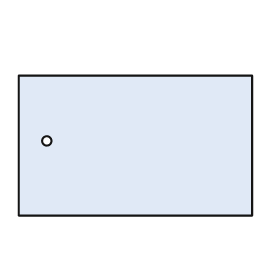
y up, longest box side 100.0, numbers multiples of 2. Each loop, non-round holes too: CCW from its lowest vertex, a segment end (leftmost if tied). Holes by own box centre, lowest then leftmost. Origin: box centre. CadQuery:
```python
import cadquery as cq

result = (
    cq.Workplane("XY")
    .moveTo(-50.0, -30.0)
    .lineTo(50.0, -30.0)
    .lineTo(50.0, 30.0)
    .lineTo(-50.0, 30.0)
    .close()
    .moveTo(-38.0, 2.0)
    .circle(2.0)
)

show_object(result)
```